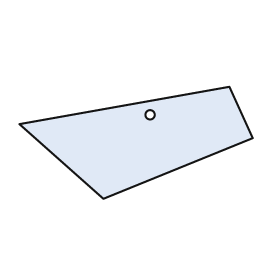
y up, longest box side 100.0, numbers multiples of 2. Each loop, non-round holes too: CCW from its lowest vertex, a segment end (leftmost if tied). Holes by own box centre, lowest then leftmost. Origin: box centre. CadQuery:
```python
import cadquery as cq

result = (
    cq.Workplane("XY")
    .moveTo(-14.0, -24.0)
    .lineTo(50.0, 2.0)
    .lineTo(40.0, 24.0)
    .lineTo(-50.0, 8.0)
    .close()
    .moveTo(6.0, 12.0)
    .circle(2.0)
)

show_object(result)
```